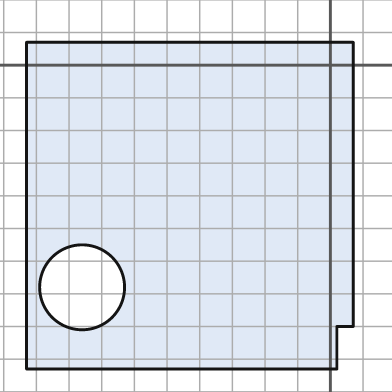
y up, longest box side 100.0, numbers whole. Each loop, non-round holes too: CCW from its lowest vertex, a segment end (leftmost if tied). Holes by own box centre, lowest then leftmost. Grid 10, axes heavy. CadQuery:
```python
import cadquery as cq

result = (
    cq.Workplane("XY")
    .moveTo(-93.0, -93.0)
    .lineTo(2.0, -93.0)
    .lineTo(2.0, -80.0)
    .lineTo(7.0, -80.0)
    .lineTo(7.0, 7.0)
    .lineTo(-93.0, 7.0)
    .close()
    .moveTo(-76.0, -68.0)
    .circle(13.0)
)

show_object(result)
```